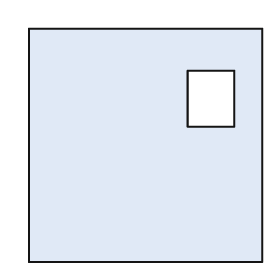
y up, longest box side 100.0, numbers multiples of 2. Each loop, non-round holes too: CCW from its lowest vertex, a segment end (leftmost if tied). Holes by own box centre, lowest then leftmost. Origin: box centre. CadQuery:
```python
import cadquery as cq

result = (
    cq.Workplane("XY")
    .moveTo(-50.0, -50.0)
    .lineTo(50.0, -50.0)
    .lineTo(50.0, 50.0)
    .lineTo(-50.0, 50.0)
    .close()
    .moveTo(18.0, 8.0)
    .lineTo(38.0, 8.0)
    .lineTo(38.0, 32.0)
    .lineTo(18.0, 32.0)
    .close()
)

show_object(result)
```